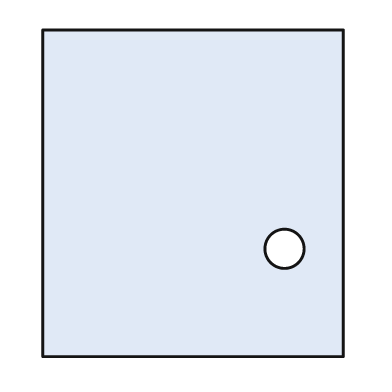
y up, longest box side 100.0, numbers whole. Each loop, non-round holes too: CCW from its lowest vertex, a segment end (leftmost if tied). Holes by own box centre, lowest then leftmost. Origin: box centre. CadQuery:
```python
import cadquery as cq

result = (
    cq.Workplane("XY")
    .moveTo(-46.0, -50.0)
    .lineTo(46.0, -50.0)
    .lineTo(46.0, 50.0)
    .lineTo(-46.0, 50.0)
    .close()
    .moveTo(28.0, -17.0)
    .circle(6.0)
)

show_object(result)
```